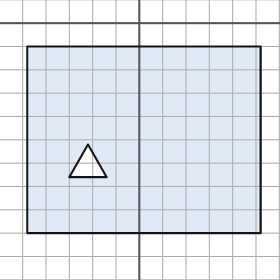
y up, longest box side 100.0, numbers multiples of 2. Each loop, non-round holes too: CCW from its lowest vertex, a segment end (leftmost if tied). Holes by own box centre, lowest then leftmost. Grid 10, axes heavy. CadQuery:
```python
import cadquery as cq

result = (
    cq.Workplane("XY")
    .moveTo(-48.0, -90.0)
    .lineTo(52.0, -90.0)
    .lineTo(52.0, -10.0)
    .lineTo(-48.0, -10.0)
    .close()
    .moveTo(-30.0, -66.0)
    .lineTo(-14.0, -66.0)
    .lineTo(-22.0, -52.0)
    .close()
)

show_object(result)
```